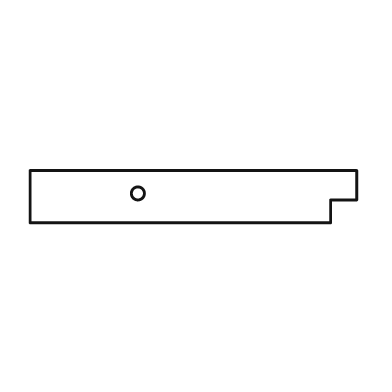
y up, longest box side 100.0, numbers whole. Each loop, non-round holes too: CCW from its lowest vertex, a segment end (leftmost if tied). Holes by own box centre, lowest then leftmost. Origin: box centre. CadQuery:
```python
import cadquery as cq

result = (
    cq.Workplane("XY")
    .moveTo(-50.0, -8.0)
    .lineTo(42.0, -8.0)
    .lineTo(42.0, -1.0)
    .lineTo(50.0, -1.0)
    .lineTo(50.0, 8.0)
    .lineTo(-50.0, 8.0)
    .close()
    .moveTo(-17.0, 1.0)
    .circle(2.0)
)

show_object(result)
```